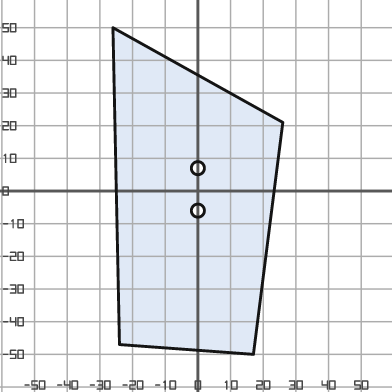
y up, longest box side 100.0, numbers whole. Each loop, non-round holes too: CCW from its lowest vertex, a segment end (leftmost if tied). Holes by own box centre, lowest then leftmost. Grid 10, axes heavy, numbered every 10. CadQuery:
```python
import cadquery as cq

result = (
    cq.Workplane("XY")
    .moveTo(17.0, -50.0)
    .lineTo(26.0, 21.0)
    .lineTo(-26.0, 50.0)
    .lineTo(-24.0, -47.0)
    .close()
    .moveTo(0.0, -6.0)
    .circle(2.0)
    .moveTo(0.0, 7.0)
    .circle(2.0)
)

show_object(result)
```